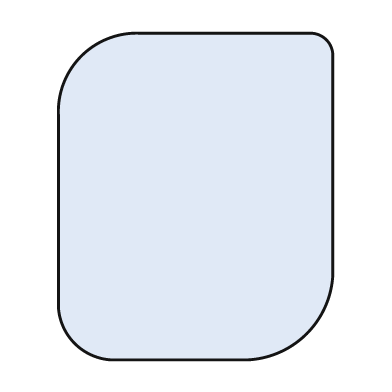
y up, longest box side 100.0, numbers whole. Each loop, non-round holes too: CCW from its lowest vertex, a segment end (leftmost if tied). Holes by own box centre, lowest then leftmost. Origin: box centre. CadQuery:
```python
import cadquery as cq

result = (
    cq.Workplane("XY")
    .moveTo(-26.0, -50.0)
    .lineTo(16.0, -50.0)
    .threePointArc((34.0, -42.0), (42.0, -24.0))
    .lineTo(42.0, 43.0)
    .threePointArc((40.0, 48.0), (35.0, 50.0))
    .lineTo(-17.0, 50.0)
    .threePointArc((-35.0, 43.0), (-42.0, 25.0))
    .lineTo(-42.0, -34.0)
    .threePointArc((-37.0, -45.0), (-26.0, -50.0))
    .close()
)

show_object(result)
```